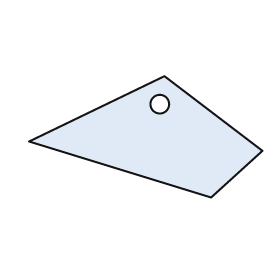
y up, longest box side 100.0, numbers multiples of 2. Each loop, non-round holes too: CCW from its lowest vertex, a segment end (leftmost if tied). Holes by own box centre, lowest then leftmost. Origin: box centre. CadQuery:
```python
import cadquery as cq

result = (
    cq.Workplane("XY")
    .moveTo(28.0, -26.0)
    .lineTo(50.0, -6.0)
    .lineTo(8.0, 26.0)
    .lineTo(-50.0, -2.0)
    .close()
    .moveTo(6.0, 14.0)
    .circle(4.0)
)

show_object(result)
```